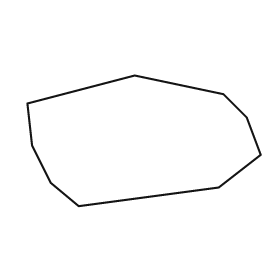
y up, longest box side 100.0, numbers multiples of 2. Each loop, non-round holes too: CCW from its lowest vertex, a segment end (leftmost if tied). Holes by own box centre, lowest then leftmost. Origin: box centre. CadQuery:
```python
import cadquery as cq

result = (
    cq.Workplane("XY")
    .moveTo(-28.0, -28.0)
    .lineTo(32.0, -20.0)
    .lineTo(50.0, -6.0)
    .lineTo(44.0, 10.0)
    .lineTo(34.0, 20.0)
    .lineTo(-4.0, 28.0)
    .lineTo(-50.0, 16.0)
    .lineTo(-48.0, -2.0)
    .lineTo(-40.0, -18.0)
    .close()
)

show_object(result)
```